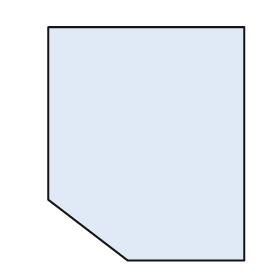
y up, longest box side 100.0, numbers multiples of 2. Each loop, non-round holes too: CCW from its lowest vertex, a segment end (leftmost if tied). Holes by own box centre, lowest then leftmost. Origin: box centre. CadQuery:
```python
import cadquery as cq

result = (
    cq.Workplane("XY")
    .moveTo(-8.0, -50.0)
    .lineTo(42.0, -50.0)
    .lineTo(42.0, 50.0)
    .lineTo(-42.0, 50.0)
    .lineTo(-42.0, -24.0)
    .close()
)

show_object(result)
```